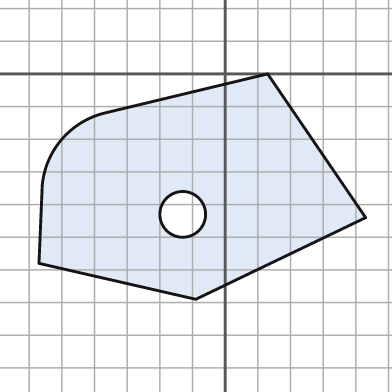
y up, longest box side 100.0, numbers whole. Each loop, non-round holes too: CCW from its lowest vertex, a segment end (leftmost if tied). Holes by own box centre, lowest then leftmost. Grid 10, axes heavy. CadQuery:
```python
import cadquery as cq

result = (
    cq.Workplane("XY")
    .moveTo(-9.0, -69.0)
    .lineTo(43.0, -44.0)
    .lineTo(13.0, 0.0)
    .lineTo(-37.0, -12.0)
    .threePointArc((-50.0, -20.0), (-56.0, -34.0))
    .lineTo(-57.0, -58.0)
    .close()
    .moveTo(-13.0, -43.0)
    .circle(7.0)
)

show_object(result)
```